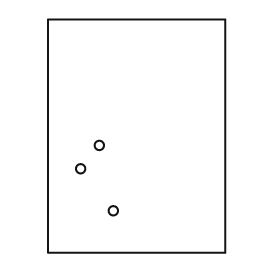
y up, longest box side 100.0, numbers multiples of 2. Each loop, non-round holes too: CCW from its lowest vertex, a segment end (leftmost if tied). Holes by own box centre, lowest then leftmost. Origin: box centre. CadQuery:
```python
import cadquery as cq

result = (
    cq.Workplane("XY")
    .moveTo(-38.0, -50.0)
    .lineTo(38.0, -50.0)
    .lineTo(38.0, 50.0)
    .lineTo(-38.0, 50.0)
    .close()
    .moveTo(-10.0, -32.0)
    .circle(2.0)
    .moveTo(-24.0, -14.0)
    .circle(2.0)
    .moveTo(-16.0, -4.0)
    .circle(2.0)
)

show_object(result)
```